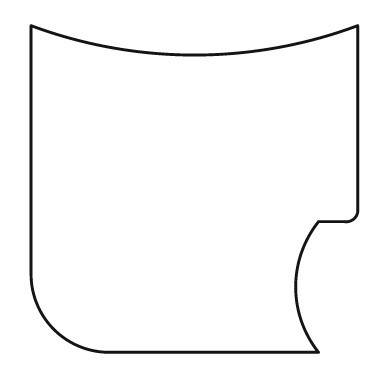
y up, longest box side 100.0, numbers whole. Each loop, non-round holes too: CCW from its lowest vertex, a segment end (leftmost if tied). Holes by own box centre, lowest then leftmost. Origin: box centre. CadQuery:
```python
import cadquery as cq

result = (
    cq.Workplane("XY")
    .moveTo(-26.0, -50.0)
    .lineTo(38.0, -50.0)
    .threePointArc((31.0, -30.0), (38.0, -10.0))
    .lineTo(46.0, -10.0)
    .threePointArc((49.0, -9.0), (50.0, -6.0))
    .lineTo(50.0, 50.0)
    .threePointArc((0.0, 41.0), (-50.0, 50.0))
    .lineTo(-50.0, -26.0)
    .threePointArc((-43.0, -43.0), (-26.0, -50.0))
    .close()
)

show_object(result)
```